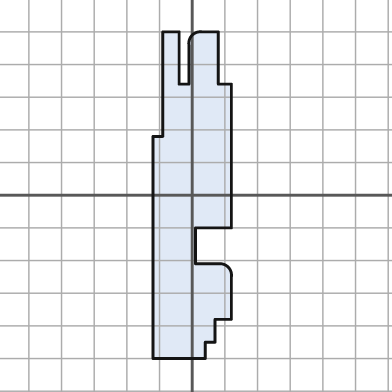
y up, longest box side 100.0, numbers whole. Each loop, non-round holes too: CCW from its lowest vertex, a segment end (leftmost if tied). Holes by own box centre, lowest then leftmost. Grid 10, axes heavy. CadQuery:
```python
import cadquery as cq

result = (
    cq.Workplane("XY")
    .moveTo(-12.0, -50.0)
    .lineTo(4.0, -50.0)
    .lineTo(4.0, -45.0)
    .lineTo(7.0, -45.0)
    .lineTo(7.0, -38.0)
    .lineTo(12.0, -38.0)
    .lineTo(12.0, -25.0)
    .threePointArc((11.0, -22.0), (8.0, -21.0))
    .lineTo(1.0, -21.0)
    .lineTo(1.0, -10.0)
    .lineTo(12.0, -10.0)
    .lineTo(12.0, 34.0)
    .lineTo(8.0, 34.0)
    .lineTo(8.0, 50.0)
    .lineTo(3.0, 50.0)
    .threePointArc((0.0, 49.0), (-1.0, 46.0))
    .lineTo(-1.0, 34.0)
    .lineTo(-4.0, 34.0)
    .lineTo(-4.0, 50.0)
    .lineTo(-9.0, 50.0)
    .lineTo(-9.0, 18.0)
    .lineTo(-12.0, 18.0)
    .close()
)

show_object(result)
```